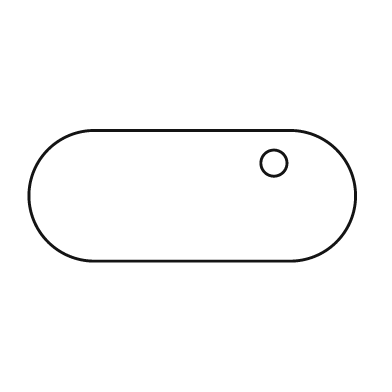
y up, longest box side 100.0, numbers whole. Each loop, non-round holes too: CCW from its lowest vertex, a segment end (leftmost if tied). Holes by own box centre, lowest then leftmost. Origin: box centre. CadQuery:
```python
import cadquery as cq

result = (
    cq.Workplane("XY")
    .moveTo(-30.0, -20.0)
    .lineTo(30.0, -20.0)
    .threePointArc((50.0, 0.0), (30.0, 20.0))
    .lineTo(-30.0, 20.0)
    .threePointArc((-50.0, 0.0), (-30.0, -20.0))
    .close()
    .moveTo(25.0, 10.0)
    .circle(4.0)
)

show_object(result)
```